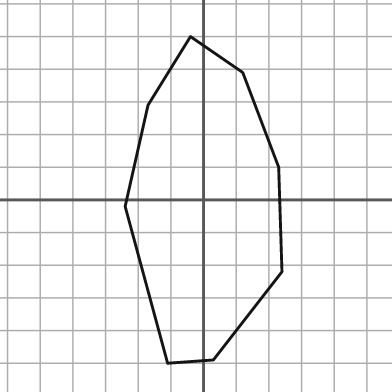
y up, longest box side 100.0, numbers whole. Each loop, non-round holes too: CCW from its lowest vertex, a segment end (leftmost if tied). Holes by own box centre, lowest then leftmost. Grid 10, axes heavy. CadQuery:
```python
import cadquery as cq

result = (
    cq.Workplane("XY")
    .moveTo(-11.0, -50.0)
    .lineTo(3.0, -49.0)
    .lineTo(24.0, -22.0)
    .lineTo(23.0, 10.0)
    .lineTo(12.0, 39.0)
    .lineTo(-4.0, 50.0)
    .lineTo(-17.0, 29.0)
    .lineTo(-24.0, -2.0)
    .close()
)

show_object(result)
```